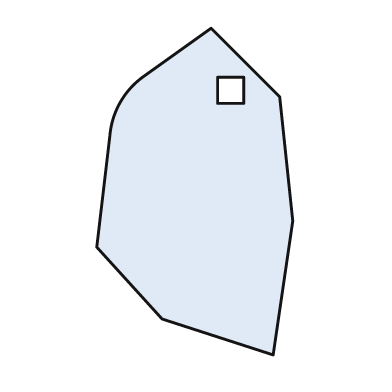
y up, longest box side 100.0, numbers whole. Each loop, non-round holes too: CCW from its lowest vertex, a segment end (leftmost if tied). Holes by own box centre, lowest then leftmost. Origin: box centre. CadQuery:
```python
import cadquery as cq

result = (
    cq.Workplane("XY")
    .moveTo(24.0, -50.0)
    .lineTo(30.0, -9.0)
    .lineTo(26.0, 29.0)
    .lineTo(5.0, 50.0)
    .lineTo(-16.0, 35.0)
    .threePointArc((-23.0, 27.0), (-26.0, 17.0))
    .lineTo(-30.0, -17.0)
    .lineTo(-10.0, -39.0)
    .close()
    .moveTo(7.0, 27.0)
    .lineTo(15.0, 27.0)
    .lineTo(15.0, 35.0)
    .lineTo(7.0, 35.0)
    .close()
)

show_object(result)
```